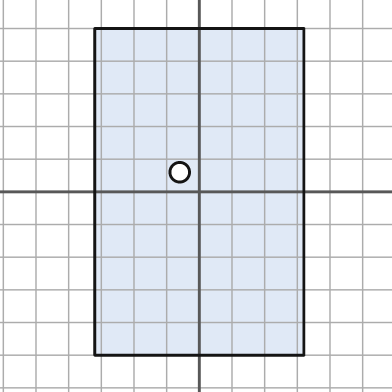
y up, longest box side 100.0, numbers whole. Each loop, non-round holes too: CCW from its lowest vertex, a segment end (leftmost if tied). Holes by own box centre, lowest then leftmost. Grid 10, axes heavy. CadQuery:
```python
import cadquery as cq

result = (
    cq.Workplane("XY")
    .moveTo(-32.0, -50.0)
    .lineTo(32.0, -50.0)
    .lineTo(32.0, 50.0)
    .lineTo(-32.0, 50.0)
    .close()
    .moveTo(-6.0, 6.0)
    .circle(3.0)
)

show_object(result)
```